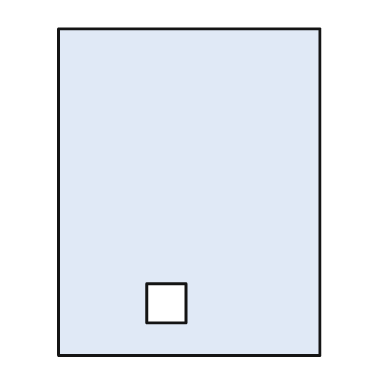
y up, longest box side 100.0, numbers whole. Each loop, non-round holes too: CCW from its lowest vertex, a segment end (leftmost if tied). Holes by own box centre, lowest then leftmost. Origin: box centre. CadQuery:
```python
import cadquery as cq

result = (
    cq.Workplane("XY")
    .moveTo(-40.0, -50.0)
    .lineTo(40.0, -50.0)
    .lineTo(40.0, 50.0)
    .lineTo(-40.0, 50.0)
    .close()
    .moveTo(-13.0, -40.0)
    .lineTo(-1.0, -40.0)
    .lineTo(-1.0, -28.0)
    .lineTo(-13.0, -28.0)
    .close()
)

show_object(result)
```